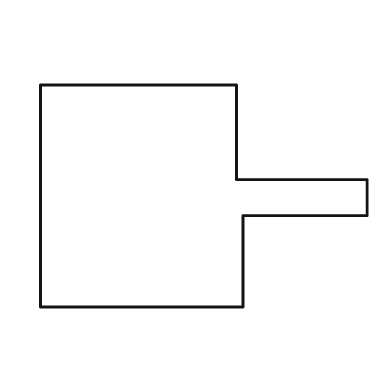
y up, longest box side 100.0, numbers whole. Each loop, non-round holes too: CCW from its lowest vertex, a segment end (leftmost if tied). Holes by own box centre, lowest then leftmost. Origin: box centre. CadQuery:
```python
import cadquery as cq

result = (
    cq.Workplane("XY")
    .moveTo(-50.0, -34.0)
    .lineTo(12.0, -34.0)
    .lineTo(12.0, -6.0)
    .lineTo(50.0, -6.0)
    .lineTo(50.0, 5.0)
    .lineTo(10.0, 5.0)
    .lineTo(10.0, 34.0)
    .lineTo(-50.0, 34.0)
    .close()
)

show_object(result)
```